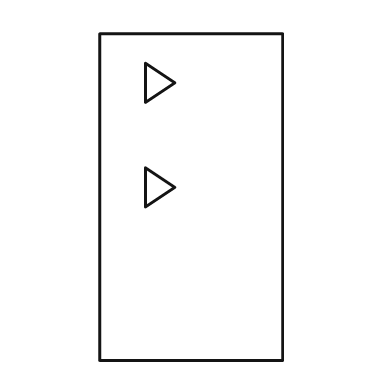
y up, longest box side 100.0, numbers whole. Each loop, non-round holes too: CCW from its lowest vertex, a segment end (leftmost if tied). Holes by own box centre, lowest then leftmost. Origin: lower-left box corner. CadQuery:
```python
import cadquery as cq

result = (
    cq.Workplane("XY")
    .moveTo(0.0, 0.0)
    .lineTo(56.0, 0.0)
    .lineTo(56.0, 100.0)
    .lineTo(0.0, 100.0)
    .close()
    .moveTo(14.0, 47.0)
    .lineTo(23.0, 53.0)
    .lineTo(14.0, 59.0)
    .close()
    .moveTo(14.0, 79.0)
    .lineTo(23.0, 85.0)
    .lineTo(14.0, 91.0)
    .close()
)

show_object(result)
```